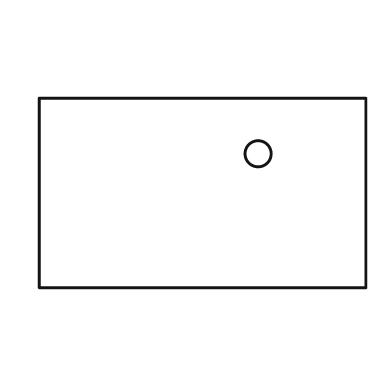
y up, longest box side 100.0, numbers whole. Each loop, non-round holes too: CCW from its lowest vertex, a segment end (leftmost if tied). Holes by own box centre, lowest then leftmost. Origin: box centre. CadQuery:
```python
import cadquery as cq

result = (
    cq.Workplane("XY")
    .moveTo(-50.0, -29.0)
    .lineTo(50.0, -29.0)
    .lineTo(50.0, 29.0)
    .lineTo(-50.0, 29.0)
    .close()
    .moveTo(17.0, 12.0)
    .circle(4.0)
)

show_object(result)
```